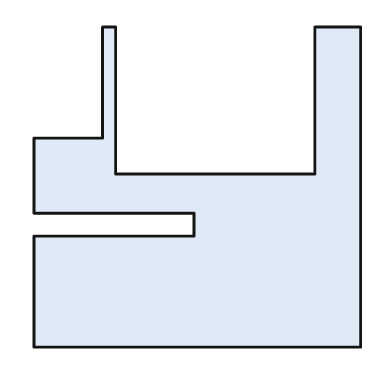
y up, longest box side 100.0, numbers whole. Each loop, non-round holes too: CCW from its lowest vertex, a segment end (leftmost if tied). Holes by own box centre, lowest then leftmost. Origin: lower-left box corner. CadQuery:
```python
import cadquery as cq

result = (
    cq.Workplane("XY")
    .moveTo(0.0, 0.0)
    .lineTo(100.0, 0.0)
    .lineTo(100.0, 98.0)
    .lineTo(86.0, 98.0)
    .lineTo(86.0, 53.0)
    .lineTo(25.0, 53.0)
    .lineTo(25.0, 98.0)
    .lineTo(21.0, 98.0)
    .lineTo(21.0, 64.0)
    .lineTo(0.0, 64.0)
    .lineTo(0.0, 41.0)
    .lineTo(49.0, 41.0)
    .lineTo(49.0, 34.0)
    .lineTo(0.0, 34.0)
    .close()
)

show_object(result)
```